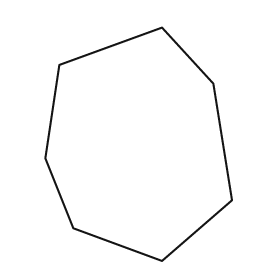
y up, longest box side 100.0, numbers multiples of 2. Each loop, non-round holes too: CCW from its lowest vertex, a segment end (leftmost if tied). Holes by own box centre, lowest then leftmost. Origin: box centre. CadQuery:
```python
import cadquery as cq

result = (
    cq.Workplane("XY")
    .moveTo(10.0, -50.0)
    .lineTo(40.0, -24.0)
    .lineTo(32.0, 26.0)
    .lineTo(10.0, 50.0)
    .lineTo(-34.0, 34.0)
    .lineTo(-40.0, -6.0)
    .lineTo(-28.0, -36.0)
    .close()
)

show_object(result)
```